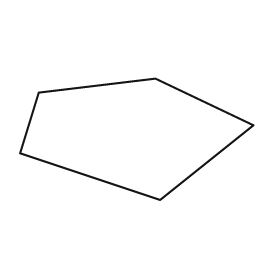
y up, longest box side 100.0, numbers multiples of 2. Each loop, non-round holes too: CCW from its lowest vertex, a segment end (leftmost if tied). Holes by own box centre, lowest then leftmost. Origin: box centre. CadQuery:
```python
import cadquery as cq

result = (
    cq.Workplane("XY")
    .moveTo(10.0, -26.0)
    .lineTo(50.0, 6.0)
    .lineTo(8.0, 26.0)
    .lineTo(-42.0, 20.0)
    .lineTo(-50.0, -6.0)
    .close()
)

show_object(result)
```